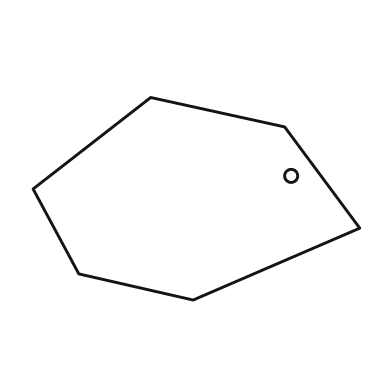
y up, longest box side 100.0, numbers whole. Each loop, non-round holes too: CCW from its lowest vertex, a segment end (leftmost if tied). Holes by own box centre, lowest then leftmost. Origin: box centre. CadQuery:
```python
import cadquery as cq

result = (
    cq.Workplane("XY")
    .moveTo(-1.0, -31.0)
    .lineTo(50.0, -9.0)
    .lineTo(27.0, 22.0)
    .lineTo(-14.0, 31.0)
    .lineTo(-50.0, 3.0)
    .lineTo(-36.0, -23.0)
    .close()
    .moveTo(29.0, 7.0)
    .circle(2.0)
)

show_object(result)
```